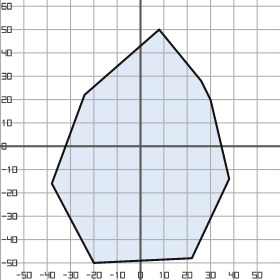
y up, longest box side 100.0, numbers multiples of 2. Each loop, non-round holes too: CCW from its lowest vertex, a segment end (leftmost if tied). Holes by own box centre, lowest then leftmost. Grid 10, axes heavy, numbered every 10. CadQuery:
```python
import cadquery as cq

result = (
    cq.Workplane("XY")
    .moveTo(-20.0, -50.0)
    .lineTo(22.0, -48.0)
    .lineTo(38.0, -14.0)
    .lineTo(30.0, 20.0)
    .lineTo(26.0, 28.0)
    .lineTo(8.0, 50.0)
    .lineTo(-24.0, 22.0)
    .lineTo(-38.0, -16.0)
    .close()
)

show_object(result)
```